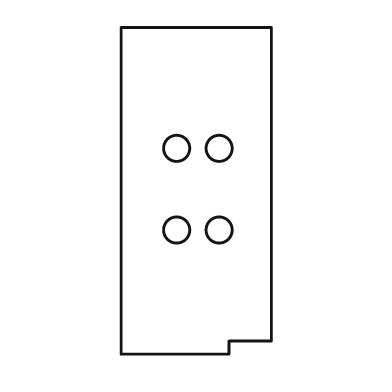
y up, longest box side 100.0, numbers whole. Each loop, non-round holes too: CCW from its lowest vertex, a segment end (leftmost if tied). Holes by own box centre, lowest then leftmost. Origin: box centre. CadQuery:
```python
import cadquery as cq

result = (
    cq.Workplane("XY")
    .moveTo(-23.0, -50.0)
    .lineTo(10.0, -50.0)
    .lineTo(10.0, -46.0)
    .lineTo(23.0, -46.0)
    .lineTo(23.0, 50.0)
    .lineTo(-23.0, 50.0)
    .close()
    .moveTo(-6.0, -12.0)
    .circle(4.0)
    .moveTo(7.0, -12.0)
    .circle(4.0)
    .moveTo(-6.0, 13.0)
    .circle(4.0)
    .moveTo(7.0, 13.0)
    .circle(4.0)
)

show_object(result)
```